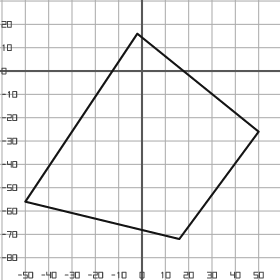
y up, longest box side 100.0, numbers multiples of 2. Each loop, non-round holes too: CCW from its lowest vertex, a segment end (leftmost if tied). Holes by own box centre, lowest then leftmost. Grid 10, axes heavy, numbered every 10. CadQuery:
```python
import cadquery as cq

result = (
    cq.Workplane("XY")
    .moveTo(16.0, -72.0)
    .lineTo(50.0, -26.0)
    .lineTo(-2.0, 16.0)
    .lineTo(-50.0, -56.0)
    .close()
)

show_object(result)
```